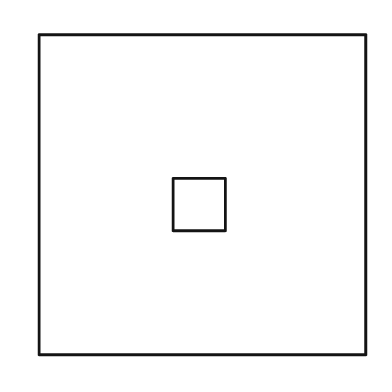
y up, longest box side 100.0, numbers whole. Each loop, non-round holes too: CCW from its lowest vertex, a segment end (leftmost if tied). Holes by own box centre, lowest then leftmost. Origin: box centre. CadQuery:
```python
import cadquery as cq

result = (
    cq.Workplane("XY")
    .moveTo(-50.0, -49.0)
    .lineTo(50.0, -49.0)
    .lineTo(50.0, 49.0)
    .lineTo(-50.0, 49.0)
    .close()
    .moveTo(-9.0, -11.0)
    .lineTo(7.0, -11.0)
    .lineTo(7.0, 5.0)
    .lineTo(-9.0, 5.0)
    .close()
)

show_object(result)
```